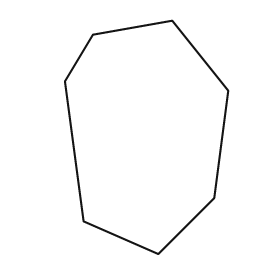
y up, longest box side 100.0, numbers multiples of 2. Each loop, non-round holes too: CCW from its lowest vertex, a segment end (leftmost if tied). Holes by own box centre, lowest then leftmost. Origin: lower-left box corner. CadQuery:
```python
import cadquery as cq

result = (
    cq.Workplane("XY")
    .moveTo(40.0, 0.0)
    .lineTo(64.0, 24.0)
    .lineTo(70.0, 70.0)
    .lineTo(46.0, 100.0)
    .lineTo(12.0, 94.0)
    .lineTo(0.0, 74.0)
    .lineTo(8.0, 14.0)
    .close()
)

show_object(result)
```